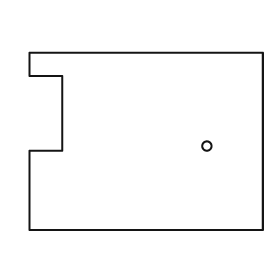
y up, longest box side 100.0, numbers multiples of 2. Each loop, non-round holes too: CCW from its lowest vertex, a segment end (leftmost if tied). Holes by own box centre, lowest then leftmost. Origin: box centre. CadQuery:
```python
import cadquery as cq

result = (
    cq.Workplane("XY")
    .moveTo(-50.0, -38.0)
    .lineTo(50.0, -38.0)
    .lineTo(50.0, 38.0)
    .lineTo(-50.0, 38.0)
    .lineTo(-50.0, 28.0)
    .lineTo(-36.0, 28.0)
    .lineTo(-36.0, -4.0)
    .lineTo(-50.0, -4.0)
    .close()
    .moveTo(26.0, -2.0)
    .circle(2.0)
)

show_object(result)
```